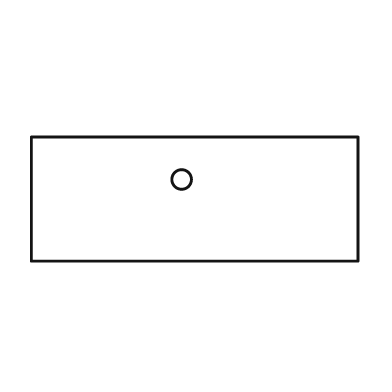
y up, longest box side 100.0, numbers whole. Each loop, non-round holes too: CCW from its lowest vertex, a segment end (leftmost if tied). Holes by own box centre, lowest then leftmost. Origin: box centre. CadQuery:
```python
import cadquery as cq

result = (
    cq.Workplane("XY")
    .moveTo(-50.0, -19.0)
    .lineTo(50.0, -19.0)
    .lineTo(50.0, 19.0)
    .lineTo(-50.0, 19.0)
    .close()
    .moveTo(-4.0, 6.0)
    .circle(3.0)
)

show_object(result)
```